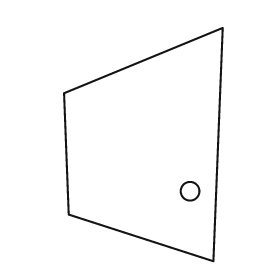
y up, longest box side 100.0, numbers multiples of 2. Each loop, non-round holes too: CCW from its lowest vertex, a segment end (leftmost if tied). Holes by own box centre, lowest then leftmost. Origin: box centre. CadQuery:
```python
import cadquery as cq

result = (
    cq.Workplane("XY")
    .moveTo(30.0, -50.0)
    .lineTo(34.0, 50.0)
    .lineTo(-34.0, 22.0)
    .lineTo(-32.0, -30.0)
    .close()
    .moveTo(20.0, -20.0)
    .circle(4.0)
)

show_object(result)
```